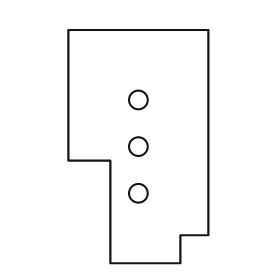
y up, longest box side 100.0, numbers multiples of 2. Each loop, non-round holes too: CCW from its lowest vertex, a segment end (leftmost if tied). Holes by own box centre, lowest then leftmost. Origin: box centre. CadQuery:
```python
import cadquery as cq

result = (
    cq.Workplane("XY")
    .moveTo(-12.0, -50.0)
    .lineTo(18.0, -50.0)
    .lineTo(18.0, -38.0)
    .lineTo(30.0, -38.0)
    .lineTo(30.0, 50.0)
    .lineTo(-30.0, 50.0)
    .lineTo(-30.0, -6.0)
    .lineTo(-12.0, -6.0)
    .close()
    .moveTo(0.0, -20.0)
    .circle(4.0)
    .moveTo(0.0, 0.0)
    .circle(4.0)
    .moveTo(0.0, 20.0)
    .circle(4.0)
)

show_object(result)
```